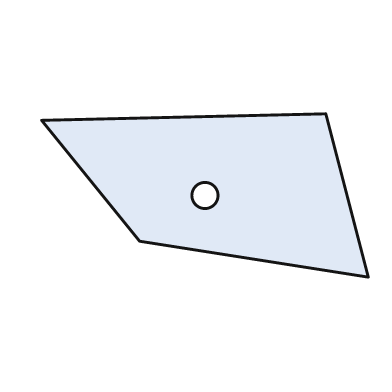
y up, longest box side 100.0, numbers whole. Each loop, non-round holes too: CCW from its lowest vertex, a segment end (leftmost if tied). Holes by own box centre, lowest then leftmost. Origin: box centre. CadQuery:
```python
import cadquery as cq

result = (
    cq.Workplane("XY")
    .moveTo(50.0, -25.0)
    .lineTo(37.0, 25.0)
    .lineTo(-50.0, 23.0)
    .lineTo(-20.0, -14.0)
    .close()
    .moveTo(0.0, 0.0)
    .circle(4.0)
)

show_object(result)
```